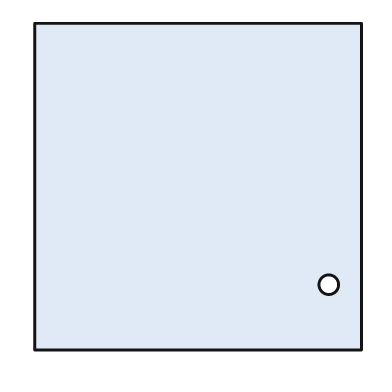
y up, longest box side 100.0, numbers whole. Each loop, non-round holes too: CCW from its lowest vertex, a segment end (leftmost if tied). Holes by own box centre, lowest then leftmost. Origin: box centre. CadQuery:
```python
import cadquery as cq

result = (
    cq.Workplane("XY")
    .moveTo(-50.0, -50.0)
    .lineTo(50.0, -50.0)
    .lineTo(50.0, 50.0)
    .lineTo(-50.0, 50.0)
    .close()
    .moveTo(40.0, -30.0)
    .circle(3.0)
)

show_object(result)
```